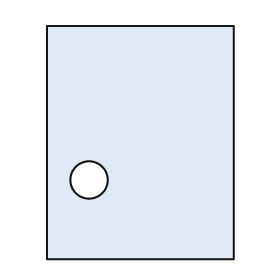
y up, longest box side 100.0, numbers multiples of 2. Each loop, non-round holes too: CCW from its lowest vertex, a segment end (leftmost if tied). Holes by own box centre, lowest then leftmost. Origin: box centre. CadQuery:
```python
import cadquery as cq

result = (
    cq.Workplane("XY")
    .moveTo(-40.0, -50.0)
    .lineTo(40.0, -50.0)
    .lineTo(40.0, 50.0)
    .lineTo(-40.0, 50.0)
    .close()
    .moveTo(-22.0, -16.0)
    .circle(8.0)
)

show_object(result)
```